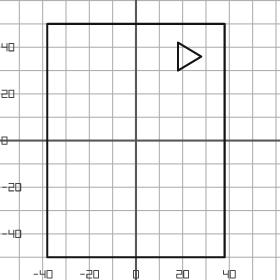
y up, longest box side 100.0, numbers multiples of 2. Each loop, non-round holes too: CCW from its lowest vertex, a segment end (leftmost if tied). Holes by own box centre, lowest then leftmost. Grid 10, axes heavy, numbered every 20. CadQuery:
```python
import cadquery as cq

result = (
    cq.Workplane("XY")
    .moveTo(-38.0, -50.0)
    .lineTo(38.0, -50.0)
    .lineTo(38.0, 50.0)
    .lineTo(-38.0, 50.0)
    .close()
    .moveTo(18.0, 30.0)
    .lineTo(28.0, 36.0)
    .lineTo(18.0, 42.0)
    .close()
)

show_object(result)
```